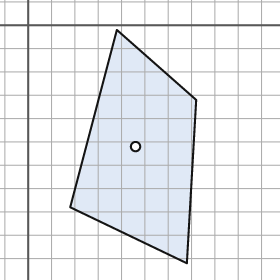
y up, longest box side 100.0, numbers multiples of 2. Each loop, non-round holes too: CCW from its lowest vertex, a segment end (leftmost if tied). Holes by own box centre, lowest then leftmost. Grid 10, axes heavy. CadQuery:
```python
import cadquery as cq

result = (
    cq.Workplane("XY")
    .moveTo(68.0, -102.0)
    .lineTo(72.0, -32.0)
    .lineTo(38.0, -2.0)
    .lineTo(18.0, -78.0)
    .close()
    .moveTo(46.0, -52.0)
    .circle(2.0)
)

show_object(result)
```